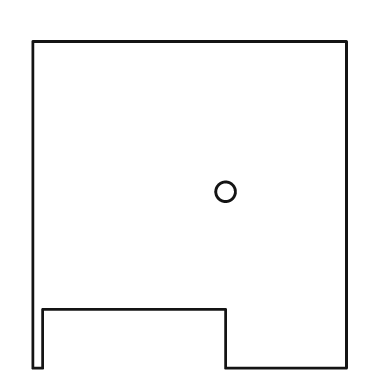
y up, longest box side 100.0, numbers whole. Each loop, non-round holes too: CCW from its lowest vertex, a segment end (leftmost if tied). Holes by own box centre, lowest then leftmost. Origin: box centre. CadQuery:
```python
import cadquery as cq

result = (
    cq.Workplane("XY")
    .moveTo(-48.0, -50.0)
    .lineTo(-45.0, -50.0)
    .lineTo(-45.0, -32.0)
    .lineTo(11.0, -32.0)
    .lineTo(11.0, -50.0)
    .lineTo(48.0, -50.0)
    .lineTo(48.0, 50.0)
    .lineTo(-48.0, 50.0)
    .close()
    .moveTo(11.0, 4.0)
    .circle(3.0)
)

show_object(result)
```